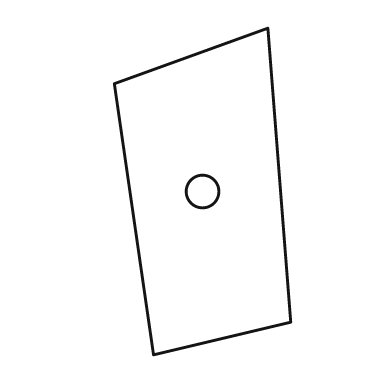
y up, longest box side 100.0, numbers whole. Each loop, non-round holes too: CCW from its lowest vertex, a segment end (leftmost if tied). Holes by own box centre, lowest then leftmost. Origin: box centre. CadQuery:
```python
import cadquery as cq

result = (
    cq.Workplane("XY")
    .moveTo(-15.0, -50.0)
    .lineTo(27.0, -40.0)
    .lineTo(20.0, 50.0)
    .lineTo(-27.0, 33.0)
    .close()
    .moveTo(0.0, 0.0)
    .circle(5.0)
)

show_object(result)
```